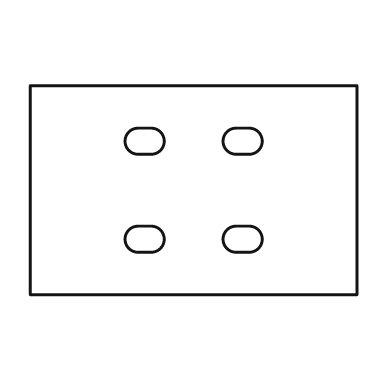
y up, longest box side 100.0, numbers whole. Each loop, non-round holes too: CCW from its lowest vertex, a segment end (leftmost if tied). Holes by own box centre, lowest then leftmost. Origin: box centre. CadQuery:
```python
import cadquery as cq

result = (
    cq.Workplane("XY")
    .moveTo(-50.0, -32.0)
    .lineTo(50.0, -32.0)
    .lineTo(50.0, 32.0)
    .lineTo(-50.0, 32.0)
    .close()
    .moveTo(-17.0, -19.0)
    .lineTo(-13.0, -19.0)
    .threePointArc((-9.0, -15.0), (-13.0, -11.0))
    .lineTo(-17.0, -11.0)
    .threePointArc((-21.0, -15.0), (-17.0, -19.0))
    .close()
    .moveTo(13.0, -19.0)
    .lineTo(17.0, -19.0)
    .threePointArc((21.0, -15.0), (17.0, -11.0))
    .lineTo(13.0, -11.0)
    .threePointArc((9.0, -15.0), (13.0, -19.0))
    .close()
    .moveTo(-17.0, 11.0)
    .lineTo(-13.0, 11.0)
    .threePointArc((-9.0, 15.0), (-13.0, 19.0))
    .lineTo(-17.0, 19.0)
    .threePointArc((-21.0, 15.0), (-17.0, 11.0))
    .close()
    .moveTo(13.0, 11.0)
    .lineTo(17.0, 11.0)
    .threePointArc((21.0, 15.0), (17.0, 19.0))
    .lineTo(13.0, 19.0)
    .threePointArc((9.0, 15.0), (13.0, 11.0))
    .close()
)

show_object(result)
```